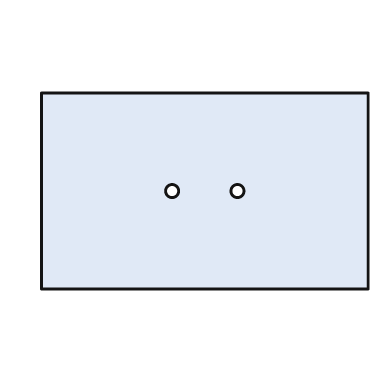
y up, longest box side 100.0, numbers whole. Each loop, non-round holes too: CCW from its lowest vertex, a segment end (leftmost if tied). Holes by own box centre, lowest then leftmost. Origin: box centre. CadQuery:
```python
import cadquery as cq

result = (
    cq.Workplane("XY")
    .moveTo(-50.0, -30.0)
    .lineTo(50.0, -30.0)
    .lineTo(50.0, 30.0)
    .lineTo(-50.0, 30.0)
    .close()
    .moveTo(-10.0, 0.0)
    .circle(2.0)
    .moveTo(10.0, 0.0)
    .circle(2.0)
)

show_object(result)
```